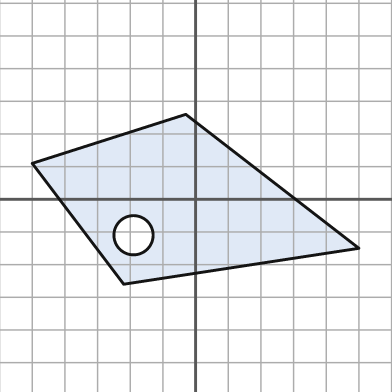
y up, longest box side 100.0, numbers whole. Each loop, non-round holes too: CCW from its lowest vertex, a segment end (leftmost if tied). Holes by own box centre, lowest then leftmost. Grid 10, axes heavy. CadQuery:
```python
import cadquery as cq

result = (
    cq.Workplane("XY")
    .moveTo(-22.0, -26.0)
    .lineTo(50.0, -15.0)
    .lineTo(-3.0, 26.0)
    .lineTo(-50.0, 11.0)
    .close()
    .moveTo(-19.0, -11.0)
    .circle(6.0)
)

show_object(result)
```